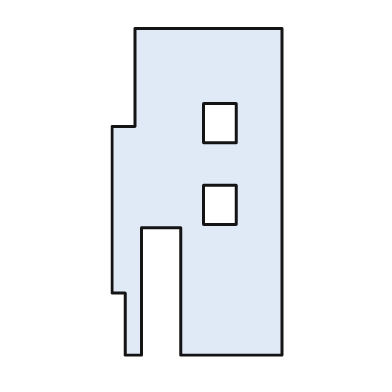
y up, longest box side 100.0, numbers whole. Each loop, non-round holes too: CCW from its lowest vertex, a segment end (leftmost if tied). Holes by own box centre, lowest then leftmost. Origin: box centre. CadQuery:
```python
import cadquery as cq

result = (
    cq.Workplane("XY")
    .moveTo(-22.0, -50.0)
    .lineTo(-17.0, -50.0)
    .lineTo(-17.0, -11.0)
    .lineTo(-5.0, -11.0)
    .lineTo(-5.0, -50.0)
    .lineTo(26.0, -50.0)
    .lineTo(26.0, 50.0)
    .lineTo(-19.0, 50.0)
    .lineTo(-19.0, 20.0)
    .lineTo(-26.0, 20.0)
    .lineTo(-26.0, -31.0)
    .lineTo(-22.0, -31.0)
    .close()
    .moveTo(2.0, -10.0)
    .lineTo(12.0, -10.0)
    .lineTo(12.0, 2.0)
    .lineTo(2.0, 2.0)
    .close()
    .moveTo(2.0, 15.0)
    .lineTo(12.0, 15.0)
    .lineTo(12.0, 27.0)
    .lineTo(2.0, 27.0)
    .close()
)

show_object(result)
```